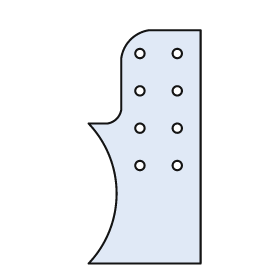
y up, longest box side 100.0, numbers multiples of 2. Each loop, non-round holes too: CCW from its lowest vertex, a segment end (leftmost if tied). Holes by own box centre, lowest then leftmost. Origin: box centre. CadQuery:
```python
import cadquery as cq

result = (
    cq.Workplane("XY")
    .moveTo(-24.0, -50.0)
    .lineTo(24.0, -50.0)
    .lineTo(24.0, 50.0)
    .lineTo(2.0, 50.0)
    .threePointArc((-6.0, 46.0), (-10.0, 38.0))
    .lineTo(-10.0, 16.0)
    .threePointArc((-12.0, 12.0), (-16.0, 10.0))
    .lineTo(-24.0, 10.0)
    .threePointArc((-12.0, -20.0), (-24.0, -50.0))
    .close()
    .moveTo(-2.0, -8.0)
    .circle(2.0)
    .moveTo(14.0, -8.0)
    .circle(2.0)
    .moveTo(-2.0, 8.0)
    .circle(2.0)
    .moveTo(14.0, 8.0)
    .circle(2.0)
    .moveTo(-2.0, 24.0)
    .circle(2.0)
    .moveTo(14.0, 24.0)
    .circle(2.0)
    .moveTo(-2.0, 40.0)
    .circle(2.0)
    .moveTo(14.0, 40.0)
    .circle(2.0)
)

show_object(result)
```